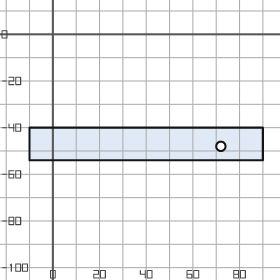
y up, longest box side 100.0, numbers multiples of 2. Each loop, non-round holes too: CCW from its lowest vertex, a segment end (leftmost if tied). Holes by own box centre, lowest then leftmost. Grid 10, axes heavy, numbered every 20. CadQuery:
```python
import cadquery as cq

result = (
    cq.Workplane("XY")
    .moveTo(-10.0, -54.0)
    .lineTo(90.0, -54.0)
    .lineTo(90.0, -40.0)
    .lineTo(-10.0, -40.0)
    .close()
    .moveTo(72.0, -48.0)
    .circle(2.0)
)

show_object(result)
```